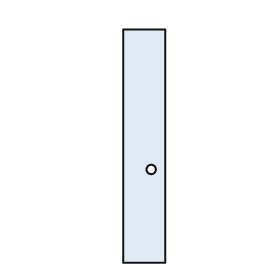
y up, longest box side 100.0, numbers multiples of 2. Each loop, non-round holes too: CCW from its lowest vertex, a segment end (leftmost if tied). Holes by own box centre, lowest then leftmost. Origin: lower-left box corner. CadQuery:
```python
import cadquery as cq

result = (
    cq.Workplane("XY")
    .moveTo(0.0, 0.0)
    .lineTo(18.0, 0.0)
    .lineTo(18.0, 100.0)
    .lineTo(0.0, 100.0)
    .close()
    .moveTo(12.0, 40.0)
    .circle(2.0)
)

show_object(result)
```